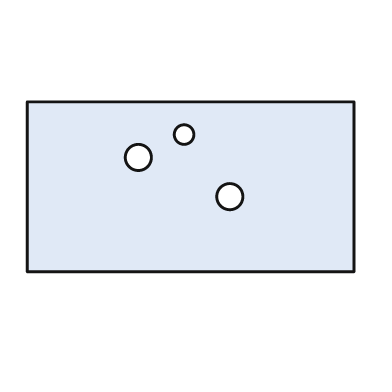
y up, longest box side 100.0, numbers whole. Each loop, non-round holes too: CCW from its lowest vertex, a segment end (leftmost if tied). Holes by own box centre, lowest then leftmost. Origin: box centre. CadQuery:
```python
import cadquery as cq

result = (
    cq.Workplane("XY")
    .moveTo(-50.0, -26.0)
    .lineTo(50.0, -26.0)
    .lineTo(50.0, 26.0)
    .lineTo(-50.0, 26.0)
    .close()
    .moveTo(12.0, -3.0)
    .circle(4.0)
    .moveTo(-16.0, 9.0)
    .circle(4.0)
    .moveTo(-2.0, 16.0)
    .circle(3.0)
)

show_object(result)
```